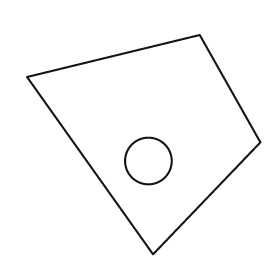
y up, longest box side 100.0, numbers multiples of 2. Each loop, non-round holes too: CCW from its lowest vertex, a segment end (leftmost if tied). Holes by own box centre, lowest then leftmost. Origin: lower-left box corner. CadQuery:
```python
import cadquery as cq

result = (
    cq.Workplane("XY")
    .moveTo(54.0, 0.0)
    .lineTo(100.0, 48.0)
    .lineTo(74.0, 94.0)
    .lineTo(0.0, 76.0)
    .close()
    .moveTo(52.0, 40.0)
    .circle(10.0)
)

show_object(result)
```